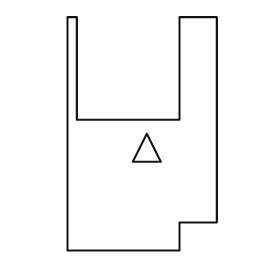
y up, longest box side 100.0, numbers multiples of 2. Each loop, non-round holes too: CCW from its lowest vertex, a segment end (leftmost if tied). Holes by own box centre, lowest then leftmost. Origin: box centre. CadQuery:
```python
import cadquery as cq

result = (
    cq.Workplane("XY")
    .moveTo(-32.0, -50.0)
    .lineTo(16.0, -50.0)
    .lineTo(16.0, -38.0)
    .lineTo(32.0, -38.0)
    .lineTo(32.0, 50.0)
    .lineTo(16.0, 50.0)
    .lineTo(16.0, 6.0)
    .lineTo(-28.0, 6.0)
    .lineTo(-28.0, 50.0)
    .lineTo(-32.0, 50.0)
    .close()
    .moveTo(-4.0, -12.0)
    .lineTo(8.0, -12.0)
    .lineTo(2.0, 0.0)
    .close()
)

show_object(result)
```